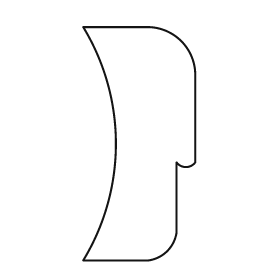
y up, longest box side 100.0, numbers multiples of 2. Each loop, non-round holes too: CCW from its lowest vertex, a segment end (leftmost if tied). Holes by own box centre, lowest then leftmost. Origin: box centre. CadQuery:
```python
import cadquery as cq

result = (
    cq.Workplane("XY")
    .moveTo(-24.0, -50.0)
    .lineTo(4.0, -50.0)
    .threePointArc((12.0, -46.0), (16.0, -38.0))
    .lineTo(16.0, -8.0)
    .threePointArc((20.0, -10.0), (24.0, -8.0))
    .lineTo(24.0, 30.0)
    .threePointArc((18.0, 44.0), (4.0, 50.0))
    .lineTo(-24.0, 50.0)
    .threePointArc((-10.0, 0.0), (-24.0, -50.0))
    .close()
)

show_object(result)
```